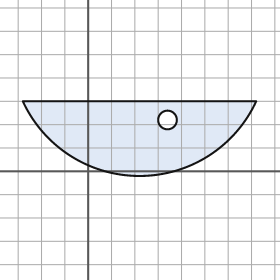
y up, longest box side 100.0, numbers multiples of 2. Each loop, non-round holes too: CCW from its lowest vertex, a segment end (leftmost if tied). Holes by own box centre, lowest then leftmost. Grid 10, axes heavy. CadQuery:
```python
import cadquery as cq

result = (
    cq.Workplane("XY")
    .moveTo(-28.0, 30.0)
    .threePointArc((22.0, -2.0), (72.0, 30.0))
    .close()
    .moveTo(34.0, 22.0)
    .circle(4.0)
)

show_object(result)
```